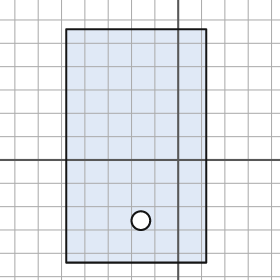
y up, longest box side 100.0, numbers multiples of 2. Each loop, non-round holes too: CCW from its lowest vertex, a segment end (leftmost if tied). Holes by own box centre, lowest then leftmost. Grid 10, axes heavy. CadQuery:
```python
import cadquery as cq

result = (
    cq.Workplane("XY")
    .moveTo(-48.0, -44.0)
    .lineTo(12.0, -44.0)
    .lineTo(12.0, 56.0)
    .lineTo(-48.0, 56.0)
    .close()
    .moveTo(-16.0, -26.0)
    .circle(4.0)
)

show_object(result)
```